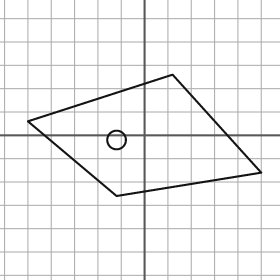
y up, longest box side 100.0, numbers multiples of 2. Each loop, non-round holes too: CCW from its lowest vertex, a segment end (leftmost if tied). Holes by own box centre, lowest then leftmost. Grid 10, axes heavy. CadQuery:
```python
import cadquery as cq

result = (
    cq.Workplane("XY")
    .moveTo(-12.0, -26.0)
    .lineTo(50.0, -16.0)
    .lineTo(12.0, 26.0)
    .lineTo(-50.0, 6.0)
    .close()
    .moveTo(-12.0, -2.0)
    .circle(4.0)
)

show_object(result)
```